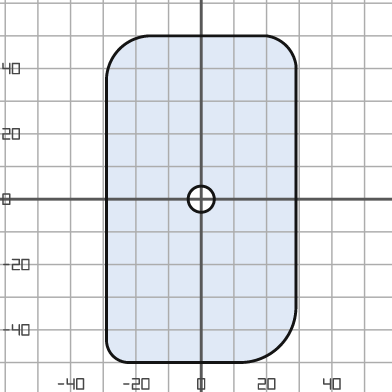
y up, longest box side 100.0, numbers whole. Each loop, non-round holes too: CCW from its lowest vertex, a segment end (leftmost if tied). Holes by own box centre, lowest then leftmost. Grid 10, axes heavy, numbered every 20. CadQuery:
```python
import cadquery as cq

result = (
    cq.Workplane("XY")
    .moveTo(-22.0, -50.0)
    .lineTo(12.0, -50.0)
    .threePointArc((24.0, -45.0), (29.0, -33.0))
    .lineTo(29.0, 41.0)
    .threePointArc((26.0, 47.0), (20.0, 50.0))
    .lineTo(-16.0, 50.0)
    .threePointArc((-25.0, 46.0), (-29.0, 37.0))
    .lineTo(-29.0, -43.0)
    .threePointArc((-27.0, -48.0), (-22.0, -50.0))
    .close()
    .moveTo(0.0, 0.0)
    .circle(4.0)
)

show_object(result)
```